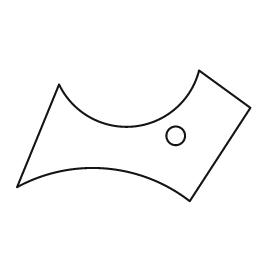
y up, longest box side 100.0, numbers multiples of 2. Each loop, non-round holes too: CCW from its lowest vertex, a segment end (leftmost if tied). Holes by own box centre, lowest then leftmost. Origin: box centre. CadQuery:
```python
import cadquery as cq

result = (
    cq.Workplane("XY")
    .moveTo(24.0, -28.0)
    .lineTo(50.0, 12.0)
    .lineTo(28.0, 28.0)
    .threePointArc((0.0, 4.0), (-32.0, 22.0))
    .lineTo(-50.0, -22.0)
    .threePointArc((-12.0, -14.0), (24.0, -28.0))
    .close()
    .moveTo(18.0, 0.0)
    .circle(4.0)
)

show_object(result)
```